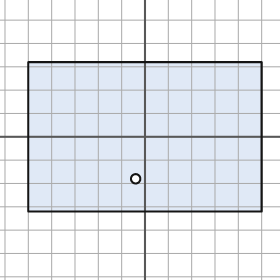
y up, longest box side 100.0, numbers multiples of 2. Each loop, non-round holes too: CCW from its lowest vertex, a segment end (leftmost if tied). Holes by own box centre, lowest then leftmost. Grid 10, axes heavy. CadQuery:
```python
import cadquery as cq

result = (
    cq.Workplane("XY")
    .moveTo(-50.0, -32.0)
    .lineTo(50.0, -32.0)
    .lineTo(50.0, 32.0)
    .lineTo(-50.0, 32.0)
    .close()
    .moveTo(-4.0, -18.0)
    .circle(2.0)
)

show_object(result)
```